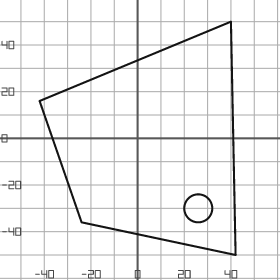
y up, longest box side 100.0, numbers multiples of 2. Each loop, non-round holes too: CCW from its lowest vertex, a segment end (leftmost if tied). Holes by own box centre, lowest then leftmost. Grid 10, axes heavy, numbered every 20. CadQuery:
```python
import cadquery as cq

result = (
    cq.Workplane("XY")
    .moveTo(42.0, -50.0)
    .lineTo(40.0, 50.0)
    .lineTo(-42.0, 16.0)
    .lineTo(-24.0, -36.0)
    .close()
    .moveTo(26.0, -30.0)
    .circle(6.0)
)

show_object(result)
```